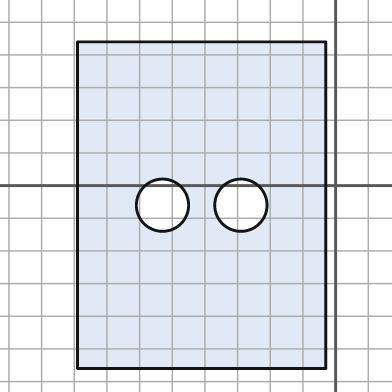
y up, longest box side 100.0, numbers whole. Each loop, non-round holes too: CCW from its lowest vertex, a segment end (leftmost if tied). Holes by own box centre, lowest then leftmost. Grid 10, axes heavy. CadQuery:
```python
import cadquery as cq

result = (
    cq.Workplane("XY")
    .moveTo(-79.0, -56.0)
    .lineTo(-3.0, -56.0)
    .lineTo(-3.0, 44.0)
    .lineTo(-79.0, 44.0)
    .close()
    .moveTo(-53.0, -6.0)
    .circle(8.0)
    .moveTo(-29.0, -6.0)
    .circle(8.0)
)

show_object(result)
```